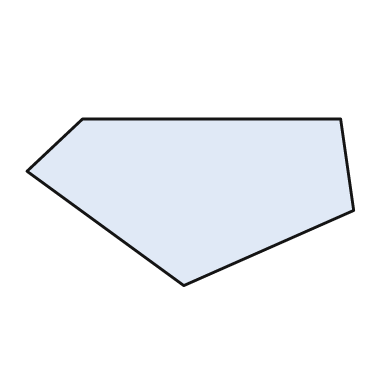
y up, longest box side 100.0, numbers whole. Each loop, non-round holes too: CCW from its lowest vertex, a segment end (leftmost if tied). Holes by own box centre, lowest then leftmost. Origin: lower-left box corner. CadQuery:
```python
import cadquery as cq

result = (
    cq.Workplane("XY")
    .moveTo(48.0, 0.0)
    .lineTo(100.0, 23.0)
    .lineTo(96.0, 51.0)
    .lineTo(17.0, 51.0)
    .lineTo(0.0, 35.0)
    .close()
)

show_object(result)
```